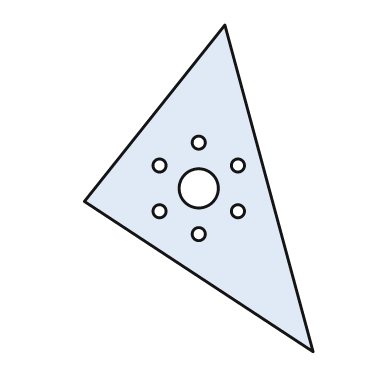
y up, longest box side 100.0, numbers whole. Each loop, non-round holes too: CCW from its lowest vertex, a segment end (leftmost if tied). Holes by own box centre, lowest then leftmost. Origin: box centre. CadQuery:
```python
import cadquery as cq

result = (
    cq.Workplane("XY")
    .moveTo(35.0, -50.0)
    .lineTo(8.0, 50.0)
    .lineTo(-35.0, -4.0)
    .close()
    .moveTo(0.0, -14.0)
    .circle(2.0)
    .moveTo(-12.0, -7.0)
    .circle(2.0)
    .moveTo(12.0, -7.0)
    .circle(2.0)
    .moveTo(0.0, 0.0)
    .circle(6.0)
    .moveTo(-12.0, 7.0)
    .circle(2.0)
    .moveTo(12.0, 7.0)
    .circle(2.0)
    .moveTo(0.0, 14.0)
    .circle(2.0)
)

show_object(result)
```